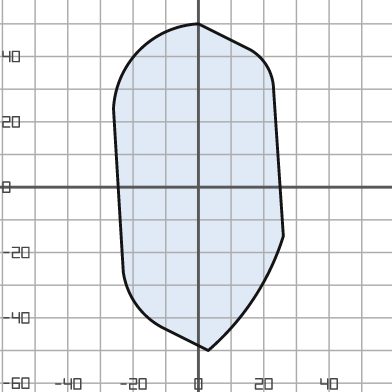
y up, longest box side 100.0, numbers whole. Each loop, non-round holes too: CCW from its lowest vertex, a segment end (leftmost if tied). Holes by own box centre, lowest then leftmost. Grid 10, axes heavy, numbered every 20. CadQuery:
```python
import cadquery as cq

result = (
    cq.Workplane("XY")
    .moveTo(3.0, -50.0)
    .threePointArc((17.0, -34.0), (26.0, -15.0))
    .lineTo(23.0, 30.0)
    .threePointArc((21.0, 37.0), (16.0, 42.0))
    .lineTo(0.0, 50.0)
    .threePointArc((-18.0, 42.0), (-26.0, 24.0))
    .lineTo(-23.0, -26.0)
    .threePointArc((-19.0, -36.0), (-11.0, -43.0))
    .close()
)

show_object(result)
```